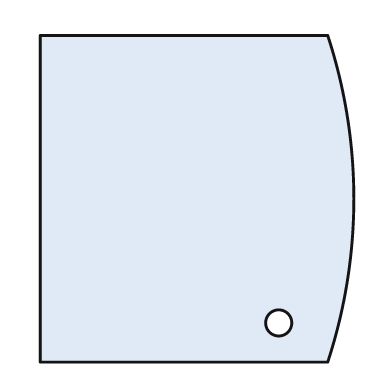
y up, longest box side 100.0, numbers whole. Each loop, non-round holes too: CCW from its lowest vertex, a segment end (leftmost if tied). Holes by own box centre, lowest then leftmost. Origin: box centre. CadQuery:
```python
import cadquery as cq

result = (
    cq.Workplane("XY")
    .moveTo(-48.0, -50.0)
    .lineTo(40.0, -50.0)
    .threePointArc((48.0, 0.0), (40.0, 50.0))
    .lineTo(-48.0, 50.0)
    .close()
    .moveTo(25.0, -38.0)
    .circle(4.0)
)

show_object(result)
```